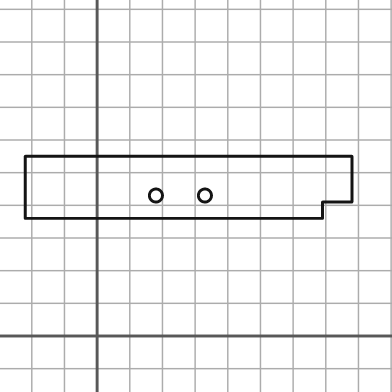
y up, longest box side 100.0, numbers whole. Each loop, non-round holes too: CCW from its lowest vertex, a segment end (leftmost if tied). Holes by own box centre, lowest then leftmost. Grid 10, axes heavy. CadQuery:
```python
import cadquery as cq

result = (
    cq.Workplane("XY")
    .moveTo(-22.0, 36.0)
    .lineTo(69.0, 36.0)
    .lineTo(69.0, 41.0)
    .lineTo(78.0, 41.0)
    .lineTo(78.0, 55.0)
    .lineTo(-22.0, 55.0)
    .close()
    .moveTo(18.0, 43.0)
    .circle(2.0)
    .moveTo(33.0, 43.0)
    .circle(2.0)
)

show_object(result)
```